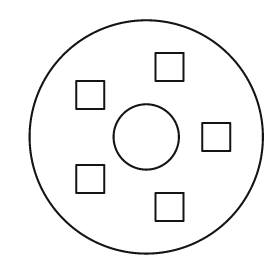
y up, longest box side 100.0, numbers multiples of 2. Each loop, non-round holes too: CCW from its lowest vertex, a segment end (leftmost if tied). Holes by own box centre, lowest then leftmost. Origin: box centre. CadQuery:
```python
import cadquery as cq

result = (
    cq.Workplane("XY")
    .moveTo(0.0, 0.0)
    .circle(50.0)
    .moveTo(4.0, -36.0)
    .lineTo(16.0, -36.0)
    .lineTo(16.0, -24.0)
    .lineTo(4.0, -24.0)
    .close()
    .moveTo(-30.0, -24.0)
    .lineTo(-18.0, -24.0)
    .lineTo(-18.0, -12.0)
    .lineTo(-30.0, -12.0)
    .close()
    .moveTo(0.0, 0.0)
    .circle(14.0)
    .moveTo(24.0, -6.0)
    .lineTo(36.0, -6.0)
    .lineTo(36.0, 6.0)
    .lineTo(24.0, 6.0)
    .close()
    .moveTo(-30.0, 12.0)
    .lineTo(-18.0, 12.0)
    .lineTo(-18.0, 24.0)
    .lineTo(-30.0, 24.0)
    .close()
    .moveTo(4.0, 24.0)
    .lineTo(16.0, 24.0)
    .lineTo(16.0, 36.0)
    .lineTo(4.0, 36.0)
    .close()
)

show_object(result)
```